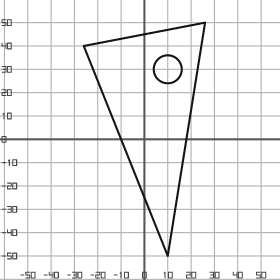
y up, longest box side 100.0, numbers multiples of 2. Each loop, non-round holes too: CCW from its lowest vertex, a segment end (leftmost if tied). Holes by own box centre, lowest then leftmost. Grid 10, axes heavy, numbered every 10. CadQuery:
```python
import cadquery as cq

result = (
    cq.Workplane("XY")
    .moveTo(10.0, -50.0)
    .lineTo(26.0, 50.0)
    .lineTo(-26.0, 40.0)
    .close()
    .moveTo(10.0, 30.0)
    .circle(6.0)
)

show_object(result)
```